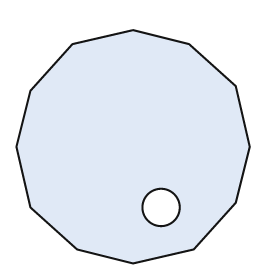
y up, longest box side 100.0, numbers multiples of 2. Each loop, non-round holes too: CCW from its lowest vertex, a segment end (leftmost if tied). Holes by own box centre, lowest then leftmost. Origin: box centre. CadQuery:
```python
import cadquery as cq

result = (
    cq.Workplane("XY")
    .moveTo(0.0, -50.0)
    .lineTo(26.0, -44.0)
    .lineTo(44.0, -24.0)
    .lineTo(50.0, 0.0)
    .lineTo(44.0, 26.0)
    .lineTo(24.0, 44.0)
    .lineTo(0.0, 50.0)
    .lineTo(-26.0, 44.0)
    .lineTo(-44.0, 24.0)
    .lineTo(-50.0, 0.0)
    .lineTo(-44.0, -26.0)
    .lineTo(-24.0, -44.0)
    .close()
    .moveTo(12.0, -26.0)
    .circle(8.0)
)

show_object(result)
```